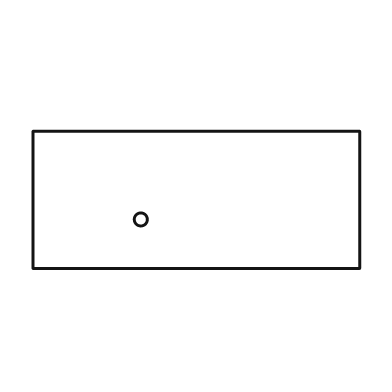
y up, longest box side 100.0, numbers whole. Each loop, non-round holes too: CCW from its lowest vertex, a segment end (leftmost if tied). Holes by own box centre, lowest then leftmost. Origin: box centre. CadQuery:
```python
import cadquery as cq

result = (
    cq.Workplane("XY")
    .moveTo(-50.0, -21.0)
    .lineTo(50.0, -21.0)
    .lineTo(50.0, 21.0)
    .lineTo(-50.0, 21.0)
    .close()
    .moveTo(-17.0, -6.0)
    .circle(2.0)
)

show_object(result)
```